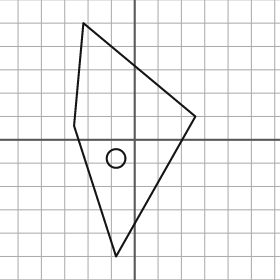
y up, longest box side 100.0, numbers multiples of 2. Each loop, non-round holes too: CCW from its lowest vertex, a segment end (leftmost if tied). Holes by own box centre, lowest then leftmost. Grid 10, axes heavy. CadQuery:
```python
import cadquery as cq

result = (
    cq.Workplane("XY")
    .moveTo(-8.0, -50.0)
    .lineTo(26.0, 10.0)
    .lineTo(-22.0, 50.0)
    .lineTo(-26.0, 6.0)
    .close()
    .moveTo(-8.0, -8.0)
    .circle(4.0)
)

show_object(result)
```